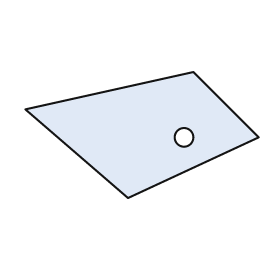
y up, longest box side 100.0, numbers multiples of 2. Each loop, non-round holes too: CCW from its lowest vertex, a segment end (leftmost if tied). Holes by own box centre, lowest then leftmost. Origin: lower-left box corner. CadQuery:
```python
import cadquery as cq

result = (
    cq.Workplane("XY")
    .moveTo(44.0, 0.0)
    .lineTo(100.0, 26.0)
    .lineTo(72.0, 54.0)
    .lineTo(0.0, 38.0)
    .close()
    .moveTo(68.0, 26.0)
    .circle(4.0)
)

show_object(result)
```